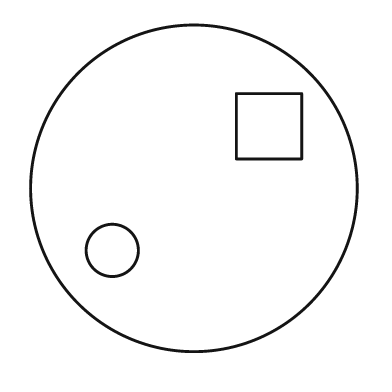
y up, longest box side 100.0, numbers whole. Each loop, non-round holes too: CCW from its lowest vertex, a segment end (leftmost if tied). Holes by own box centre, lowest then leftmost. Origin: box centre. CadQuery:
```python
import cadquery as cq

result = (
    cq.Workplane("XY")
    .moveTo(0.0, 0.0)
    .circle(50.0)
    .moveTo(-25.0, -19.0)
    .circle(8.0)
    .moveTo(13.0, 9.0)
    .lineTo(33.0, 9.0)
    .lineTo(33.0, 29.0)
    .lineTo(13.0, 29.0)
    .close()
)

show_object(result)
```